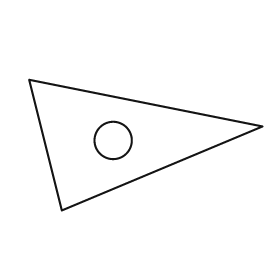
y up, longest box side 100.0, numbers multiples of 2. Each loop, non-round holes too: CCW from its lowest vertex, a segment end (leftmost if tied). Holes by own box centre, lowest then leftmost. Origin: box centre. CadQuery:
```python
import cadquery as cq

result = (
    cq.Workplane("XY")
    .moveTo(-36.0, -28.0)
    .lineTo(50.0, 8.0)
    .lineTo(-50.0, 28.0)
    .close()
    .moveTo(-14.0, 2.0)
    .circle(8.0)
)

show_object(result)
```